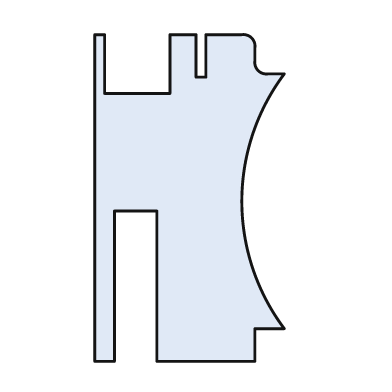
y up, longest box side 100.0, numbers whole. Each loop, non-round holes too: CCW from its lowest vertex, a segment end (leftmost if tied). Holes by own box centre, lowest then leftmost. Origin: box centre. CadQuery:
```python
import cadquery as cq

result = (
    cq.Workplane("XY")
    .moveTo(-29.0, -50.0)
    .lineTo(-23.0, -50.0)
    .lineTo(-23.0, -4.0)
    .lineTo(-10.0, -4.0)
    .lineTo(-10.0, -50.0)
    .lineTo(20.0, -50.0)
    .lineTo(20.0, -40.0)
    .lineTo(29.0, -40.0)
    .threePointArc((16.0, -1.0), (29.0, 38.0))
    .lineTo(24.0, 38.0)
    .threePointArc((21.0, 39.0), (20.0, 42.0))
    .lineTo(20.0, 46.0)
    .threePointArc((19.0, 49.0), (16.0, 50.0))
    .lineTo(5.0, 50.0)
    .lineTo(5.0, 37.0)
    .lineTo(2.0, 37.0)
    .lineTo(2.0, 50.0)
    .lineTo(-6.0, 50.0)
    .lineTo(-6.0, 32.0)
    .lineTo(-26.0, 32.0)
    .lineTo(-26.0, 50.0)
    .lineTo(-29.0, 50.0)
    .close()
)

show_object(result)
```